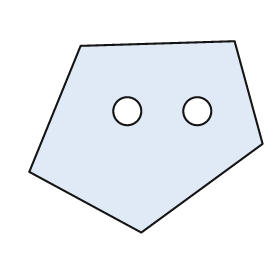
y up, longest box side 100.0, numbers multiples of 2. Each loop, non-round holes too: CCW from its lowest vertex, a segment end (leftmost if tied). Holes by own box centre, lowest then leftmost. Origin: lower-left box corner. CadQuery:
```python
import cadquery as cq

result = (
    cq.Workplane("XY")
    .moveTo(48.0, 0.0)
    .lineTo(100.0, 38.0)
    .lineTo(88.0, 82.0)
    .lineTo(22.0, 80.0)
    .lineTo(0.0, 26.0)
    .close()
    .moveTo(42.0, 52.0)
    .circle(6.0)
    .moveTo(72.0, 52.0)
    .circle(6.0)
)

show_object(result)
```